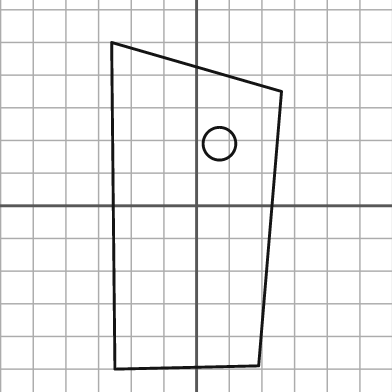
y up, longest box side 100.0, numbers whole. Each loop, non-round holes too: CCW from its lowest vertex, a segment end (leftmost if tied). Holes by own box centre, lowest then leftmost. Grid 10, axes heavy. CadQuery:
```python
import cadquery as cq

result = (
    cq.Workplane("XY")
    .moveTo(-25.0, -50.0)
    .lineTo(19.0, -49.0)
    .lineTo(26.0, 35.0)
    .lineTo(-26.0, 50.0)
    .close()
    .moveTo(7.0, 19.0)
    .circle(5.0)
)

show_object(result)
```